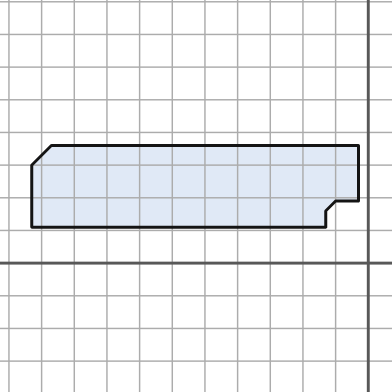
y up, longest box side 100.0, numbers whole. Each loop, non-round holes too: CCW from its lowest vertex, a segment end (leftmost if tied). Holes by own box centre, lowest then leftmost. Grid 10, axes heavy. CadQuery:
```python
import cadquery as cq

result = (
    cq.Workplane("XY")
    .moveTo(-103.0, 11.0)
    .lineTo(-13.0, 11.0)
    .lineTo(-13.0, 16.0)
    .lineTo(-10.0, 19.0)
    .lineTo(-3.0, 19.0)
    .lineTo(-3.0, 36.0)
    .lineTo(-97.0, 36.0)
    .lineTo(-103.0, 30.0)
    .close()
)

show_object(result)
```